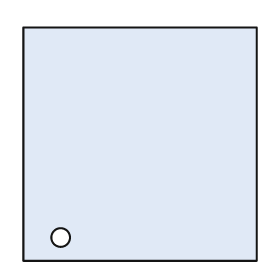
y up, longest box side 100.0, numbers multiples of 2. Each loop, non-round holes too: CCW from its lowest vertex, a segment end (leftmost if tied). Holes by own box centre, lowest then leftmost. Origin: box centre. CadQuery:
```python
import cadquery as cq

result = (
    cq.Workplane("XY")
    .moveTo(-50.0, -50.0)
    .lineTo(50.0, -50.0)
    .lineTo(50.0, 50.0)
    .lineTo(-50.0, 50.0)
    .close()
    .moveTo(-34.0, -40.0)
    .circle(4.0)
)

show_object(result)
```